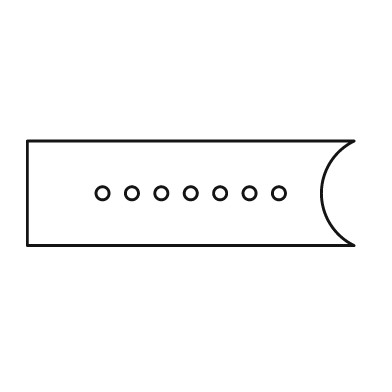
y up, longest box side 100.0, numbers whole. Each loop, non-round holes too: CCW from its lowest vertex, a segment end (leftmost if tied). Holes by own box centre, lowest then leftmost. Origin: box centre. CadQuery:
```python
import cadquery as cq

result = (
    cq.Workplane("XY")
    .moveTo(-50.0, -16.0)
    .lineTo(50.0, -16.0)
    .threePointArc((40.0, 0.0), (50.0, 16.0))
    .lineTo(-50.0, 16.0)
    .close()
    .moveTo(-27.0, 0.0)
    .circle(2.0)
    .moveTo(-18.0, 0.0)
    .circle(2.0)
    .moveTo(-9.0, 0.0)
    .circle(2.0)
    .moveTo(0.0, 0.0)
    .circle(2.0)
    .moveTo(9.0, 0.0)
    .circle(2.0)
    .moveTo(18.0, 0.0)
    .circle(2.0)
    .moveTo(27.0, 0.0)
    .circle(2.0)
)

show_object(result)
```